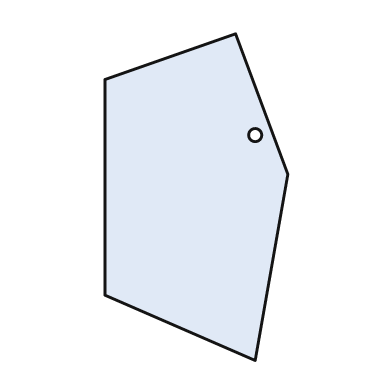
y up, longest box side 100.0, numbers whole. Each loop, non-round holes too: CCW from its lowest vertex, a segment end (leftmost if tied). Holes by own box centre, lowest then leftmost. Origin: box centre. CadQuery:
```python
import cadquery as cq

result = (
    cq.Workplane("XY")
    .moveTo(18.0, -50.0)
    .lineTo(28.0, 7.0)
    .lineTo(12.0, 50.0)
    .lineTo(-28.0, 36.0)
    .lineTo(-28.0, -30.0)
    .close()
    .moveTo(18.0, 19.0)
    .circle(2.0)
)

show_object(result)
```